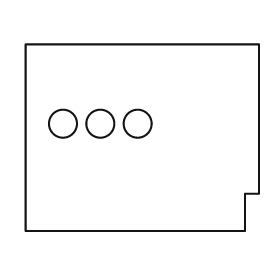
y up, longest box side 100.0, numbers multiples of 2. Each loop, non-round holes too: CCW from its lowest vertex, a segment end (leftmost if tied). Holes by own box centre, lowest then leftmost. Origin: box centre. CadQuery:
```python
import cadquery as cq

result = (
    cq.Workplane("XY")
    .moveTo(-50.0, -40.0)
    .lineTo(44.0, -40.0)
    .lineTo(44.0, -24.0)
    .lineTo(50.0, -24.0)
    .lineTo(50.0, 40.0)
    .lineTo(-50.0, 40.0)
    .close()
    .moveTo(-34.0, 6.0)
    .circle(6.0)
    .moveTo(-18.0, 6.0)
    .circle(6.0)
    .moveTo(-2.0, 6.0)
    .circle(6.0)
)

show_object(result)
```